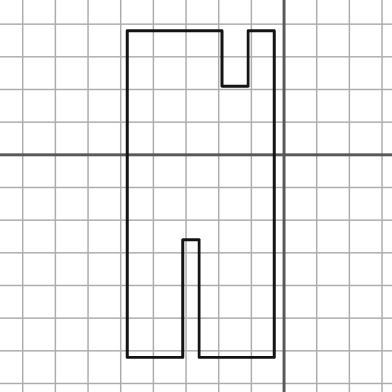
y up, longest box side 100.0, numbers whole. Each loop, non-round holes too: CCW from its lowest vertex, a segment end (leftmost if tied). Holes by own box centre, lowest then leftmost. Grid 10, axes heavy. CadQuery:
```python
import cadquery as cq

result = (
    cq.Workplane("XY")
    .moveTo(-48.0, -62.0)
    .lineTo(-31.0, -62.0)
    .lineTo(-31.0, -26.0)
    .lineTo(-26.0, -26.0)
    .lineTo(-26.0, -62.0)
    .lineTo(-3.0, -62.0)
    .lineTo(-3.0, 38.0)
    .lineTo(-11.0, 38.0)
    .lineTo(-11.0, 21.0)
    .lineTo(-19.0, 21.0)
    .lineTo(-19.0, 38.0)
    .lineTo(-48.0, 38.0)
    .close()
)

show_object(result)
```